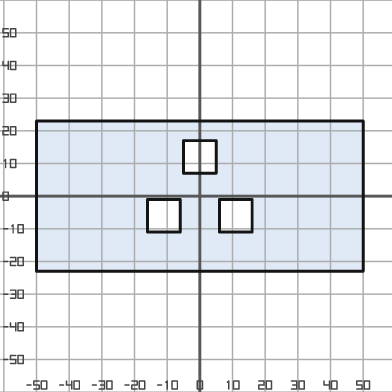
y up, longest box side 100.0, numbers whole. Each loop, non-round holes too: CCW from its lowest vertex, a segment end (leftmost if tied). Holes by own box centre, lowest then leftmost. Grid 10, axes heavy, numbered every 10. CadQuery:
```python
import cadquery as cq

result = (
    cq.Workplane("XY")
    .moveTo(-50.0, -23.0)
    .lineTo(50.0, -23.0)
    .lineTo(50.0, 23.0)
    .lineTo(-50.0, 23.0)
    .close()
    .moveTo(-16.0, -11.0)
    .lineTo(-6.0, -11.0)
    .lineTo(-6.0, -1.0)
    .lineTo(-16.0, -1.0)
    .close()
    .moveTo(6.0, -11.0)
    .lineTo(16.0, -11.0)
    .lineTo(16.0, -1.0)
    .lineTo(6.0, -1.0)
    .close()
    .moveTo(-5.0, 7.0)
    .lineTo(5.0, 7.0)
    .lineTo(5.0, 17.0)
    .lineTo(-5.0, 17.0)
    .close()
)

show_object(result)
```